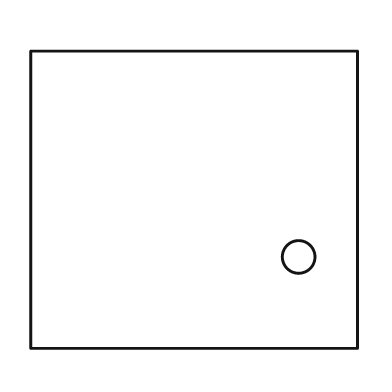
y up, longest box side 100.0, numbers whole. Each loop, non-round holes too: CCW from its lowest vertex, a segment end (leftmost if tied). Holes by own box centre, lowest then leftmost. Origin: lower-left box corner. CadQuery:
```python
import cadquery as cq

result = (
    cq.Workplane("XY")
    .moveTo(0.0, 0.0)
    .lineTo(100.0, 0.0)
    .lineTo(100.0, 91.0)
    .lineTo(0.0, 91.0)
    .close()
    .moveTo(82.0, 28.0)
    .circle(5.0)
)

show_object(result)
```